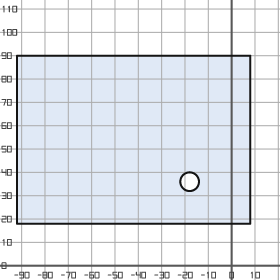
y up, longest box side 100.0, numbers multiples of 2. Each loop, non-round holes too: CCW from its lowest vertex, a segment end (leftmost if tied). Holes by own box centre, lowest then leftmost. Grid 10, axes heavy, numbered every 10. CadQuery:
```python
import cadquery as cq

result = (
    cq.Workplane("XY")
    .moveTo(-92.0, 18.0)
    .lineTo(8.0, 18.0)
    .lineTo(8.0, 90.0)
    .lineTo(-92.0, 90.0)
    .close()
    .moveTo(-18.0, 36.0)
    .circle(4.0)
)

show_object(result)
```